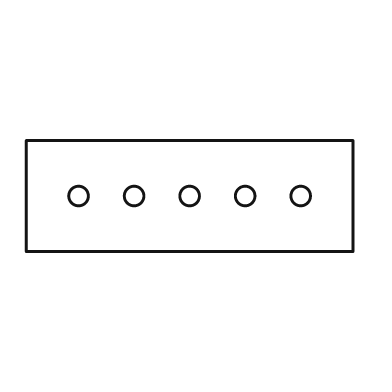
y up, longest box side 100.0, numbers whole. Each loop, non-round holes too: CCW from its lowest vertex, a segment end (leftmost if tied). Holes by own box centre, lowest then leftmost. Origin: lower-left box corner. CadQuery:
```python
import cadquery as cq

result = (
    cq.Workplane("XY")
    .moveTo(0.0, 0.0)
    .lineTo(100.0, 0.0)
    .lineTo(100.0, 34.0)
    .lineTo(0.0, 34.0)
    .close()
    .moveTo(16.0, 17.0)
    .circle(3.0)
    .moveTo(33.0, 17.0)
    .circle(3.0)
    .moveTo(50.0, 17.0)
    .circle(3.0)
    .moveTo(67.0, 17.0)
    .circle(3.0)
    .moveTo(84.0, 17.0)
    .circle(3.0)
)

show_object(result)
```